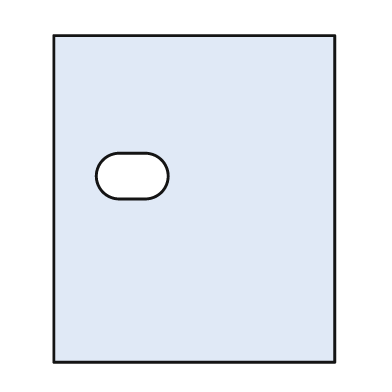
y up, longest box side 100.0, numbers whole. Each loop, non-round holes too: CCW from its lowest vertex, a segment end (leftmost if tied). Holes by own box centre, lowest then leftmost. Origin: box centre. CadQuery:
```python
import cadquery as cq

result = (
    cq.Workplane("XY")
    .moveTo(-43.0, -50.0)
    .lineTo(43.0, -50.0)
    .lineTo(43.0, 50.0)
    .lineTo(-43.0, 50.0)
    .close()
    .moveTo(-23.0, 0.0)
    .lineTo(-15.0, 0.0)
    .threePointArc((-8.0, 7.0), (-15.0, 14.0))
    .lineTo(-23.0, 14.0)
    .threePointArc((-30.0, 7.0), (-23.0, 0.0))
    .close()
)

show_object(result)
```